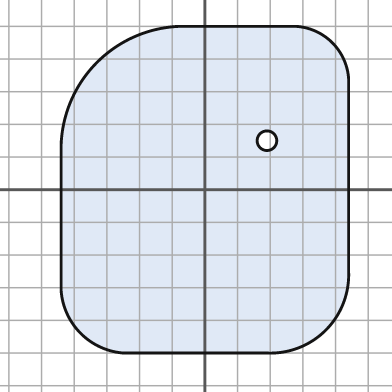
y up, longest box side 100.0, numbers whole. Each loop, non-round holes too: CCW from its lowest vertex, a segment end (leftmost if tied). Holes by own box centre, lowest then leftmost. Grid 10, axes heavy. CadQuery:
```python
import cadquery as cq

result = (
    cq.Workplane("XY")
    .moveTo(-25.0, -50.0)
    .lineTo(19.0, -50.0)
    .threePointArc((37.0, -43.0), (44.0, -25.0))
    .lineTo(44.0, 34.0)
    .threePointArc((39.0, 45.0), (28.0, 50.0))
    .lineTo(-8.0, 50.0)
    .threePointArc((-33.0, 39.0), (-44.0, 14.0))
    .lineTo(-44.0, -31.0)
    .threePointArc((-38.0, -44.0), (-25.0, -50.0))
    .close()
    .moveTo(19.0, 15.0)
    .circle(3.0)
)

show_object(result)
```